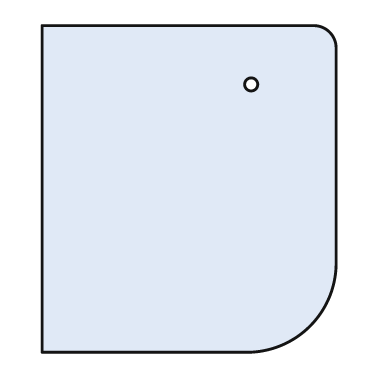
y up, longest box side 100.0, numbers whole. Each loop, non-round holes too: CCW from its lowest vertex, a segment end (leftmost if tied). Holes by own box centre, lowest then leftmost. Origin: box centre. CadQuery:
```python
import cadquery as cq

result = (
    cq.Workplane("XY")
    .moveTo(-45.0, -50.0)
    .lineTo(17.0, -50.0)
    .threePointArc((37.0, -42.0), (45.0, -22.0))
    .lineTo(45.0, 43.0)
    .threePointArc((43.0, 48.0), (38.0, 50.0))
    .lineTo(-45.0, 50.0)
    .close()
    .moveTo(19.0, 32.0)
    .circle(2.0)
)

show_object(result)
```